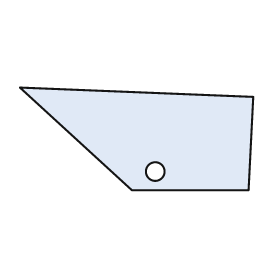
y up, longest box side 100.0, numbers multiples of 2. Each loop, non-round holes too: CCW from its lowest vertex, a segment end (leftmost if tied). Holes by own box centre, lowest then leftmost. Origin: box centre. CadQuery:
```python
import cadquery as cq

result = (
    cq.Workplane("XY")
    .moveTo(-2.0, -22.0)
    .lineTo(48.0, -22.0)
    .lineTo(50.0, 18.0)
    .lineTo(-50.0, 22.0)
    .close()
    .moveTo(8.0, -14.0)
    .circle(4.0)
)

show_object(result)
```